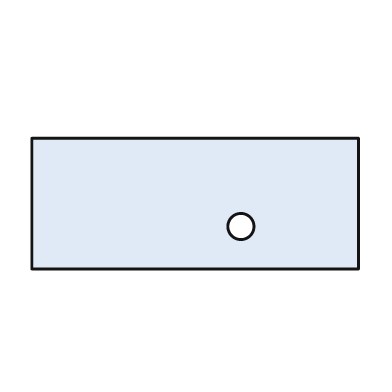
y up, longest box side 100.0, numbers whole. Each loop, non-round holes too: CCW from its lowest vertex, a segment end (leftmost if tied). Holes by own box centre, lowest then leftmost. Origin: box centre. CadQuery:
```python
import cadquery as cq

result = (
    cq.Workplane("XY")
    .moveTo(-50.0, -20.0)
    .lineTo(50.0, -20.0)
    .lineTo(50.0, 20.0)
    .lineTo(-50.0, 20.0)
    .close()
    .moveTo(14.0, -7.0)
    .circle(4.0)
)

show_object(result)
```